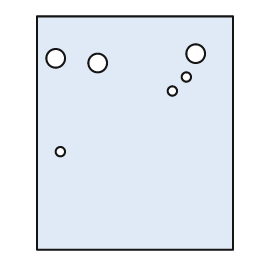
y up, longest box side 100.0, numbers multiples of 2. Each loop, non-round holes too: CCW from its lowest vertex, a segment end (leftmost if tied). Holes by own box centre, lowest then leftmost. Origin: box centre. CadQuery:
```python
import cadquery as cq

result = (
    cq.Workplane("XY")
    .moveTo(-42.0, -50.0)
    .lineTo(42.0, -50.0)
    .lineTo(42.0, 50.0)
    .lineTo(-42.0, 50.0)
    .close()
    .moveTo(-32.0, -8.0)
    .circle(2.0)
    .moveTo(16.0, 18.0)
    .circle(2.0)
    .moveTo(22.0, 24.0)
    .circle(2.0)
    .moveTo(-16.0, 30.0)
    .circle(4.0)
    .moveTo(-34.0, 32.0)
    .circle(4.0)
    .moveTo(26.0, 34.0)
    .circle(4.0)
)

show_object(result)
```